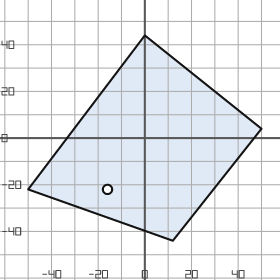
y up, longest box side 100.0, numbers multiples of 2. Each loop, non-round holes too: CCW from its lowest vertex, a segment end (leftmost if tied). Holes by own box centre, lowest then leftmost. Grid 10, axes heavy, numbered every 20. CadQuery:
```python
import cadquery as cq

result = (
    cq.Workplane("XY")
    .moveTo(12.0, -44.0)
    .lineTo(50.0, 4.0)
    .lineTo(0.0, 44.0)
    .lineTo(-50.0, -22.0)
    .close()
    .moveTo(-16.0, -22.0)
    .circle(2.0)
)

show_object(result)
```